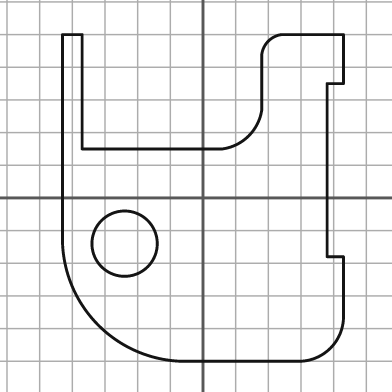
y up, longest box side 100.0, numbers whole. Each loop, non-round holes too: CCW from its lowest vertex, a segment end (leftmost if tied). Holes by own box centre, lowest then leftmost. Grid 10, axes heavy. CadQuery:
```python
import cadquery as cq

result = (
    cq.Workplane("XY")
    .moveTo(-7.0, -50.0)
    .lineTo(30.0, -50.0)
    .threePointArc((39.0, -46.0), (43.0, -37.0))
    .lineTo(43.0, -18.0)
    .lineTo(38.0, -18.0)
    .lineTo(38.0, 35.0)
    .lineTo(43.0, 35.0)
    .lineTo(43.0, 50.0)
    .lineTo(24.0, 50.0)
    .threePointArc((20.0, 48.0), (18.0, 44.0))
    .lineTo(18.0, 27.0)
    .threePointArc((14.0, 19.0), (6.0, 15.0))
    .lineTo(-37.0, 15.0)
    .lineTo(-37.0, 50.0)
    .lineTo(-43.0, 50.0)
    .lineTo(-43.0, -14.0)
    .threePointArc((-32.0, -39.0), (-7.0, -50.0))
    .close()
    .moveTo(-24.0, -14.0)
    .circle(10.0)
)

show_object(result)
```